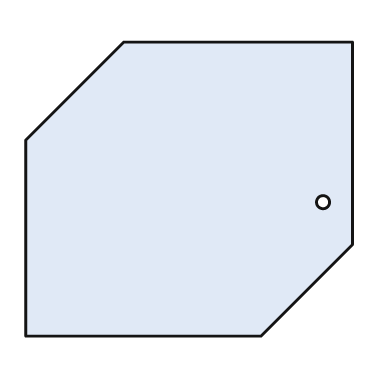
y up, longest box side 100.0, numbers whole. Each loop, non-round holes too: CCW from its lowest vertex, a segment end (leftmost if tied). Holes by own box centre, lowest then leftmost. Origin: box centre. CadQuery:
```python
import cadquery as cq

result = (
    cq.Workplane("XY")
    .moveTo(-50.0, -45.0)
    .lineTo(22.0, -45.0)
    .lineTo(50.0, -17.0)
    .lineTo(50.0, 45.0)
    .lineTo(-20.0, 45.0)
    .lineTo(-50.0, 15.0)
    .close()
    .moveTo(41.0, -4.0)
    .circle(2.0)
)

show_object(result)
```